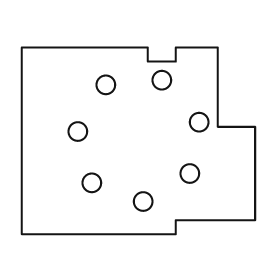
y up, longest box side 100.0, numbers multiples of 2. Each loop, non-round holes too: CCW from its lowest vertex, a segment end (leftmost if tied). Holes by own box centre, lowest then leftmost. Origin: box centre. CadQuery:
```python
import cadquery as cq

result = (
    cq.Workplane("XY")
    .moveTo(-50.0, -40.0)
    .lineTo(16.0, -40.0)
    .lineTo(16.0, -34.0)
    .lineTo(50.0, -34.0)
    .lineTo(50.0, 6.0)
    .lineTo(34.0, 6.0)
    .lineTo(34.0, 40.0)
    .lineTo(16.0, 40.0)
    .lineTo(16.0, 34.0)
    .lineTo(4.0, 34.0)
    .lineTo(4.0, 40.0)
    .lineTo(-50.0, 40.0)
    .close()
    .moveTo(2.0, -26.0)
    .circle(4.0)
    .moveTo(-20.0, -18.0)
    .circle(4.0)
    .moveTo(22.0, -14.0)
    .circle(4.0)
    .moveTo(-26.0, 4.0)
    .circle(4.0)
    .moveTo(26.0, 8.0)
    .circle(4.0)
    .moveTo(-14.0, 24.0)
    .circle(4.0)
    .moveTo(10.0, 26.0)
    .circle(4.0)
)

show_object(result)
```